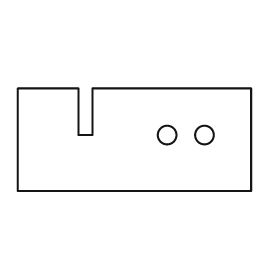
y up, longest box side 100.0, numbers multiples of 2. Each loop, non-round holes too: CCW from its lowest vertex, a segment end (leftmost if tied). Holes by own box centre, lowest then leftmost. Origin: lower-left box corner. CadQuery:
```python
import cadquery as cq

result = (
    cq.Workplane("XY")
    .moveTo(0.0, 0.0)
    .lineTo(100.0, 0.0)
    .lineTo(100.0, 44.0)
    .lineTo(32.0, 44.0)
    .lineTo(32.0, 24.0)
    .lineTo(26.0, 24.0)
    .lineTo(26.0, 44.0)
    .lineTo(0.0, 44.0)
    .close()
    .moveTo(64.0, 24.0)
    .circle(4.0)
    .moveTo(80.0, 24.0)
    .circle(4.0)
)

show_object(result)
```